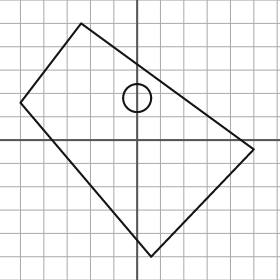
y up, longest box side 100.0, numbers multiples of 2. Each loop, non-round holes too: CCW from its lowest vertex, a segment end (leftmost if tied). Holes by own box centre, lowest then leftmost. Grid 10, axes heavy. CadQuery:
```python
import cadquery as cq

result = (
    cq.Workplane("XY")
    .moveTo(6.0, -50.0)
    .lineTo(50.0, -4.0)
    .lineTo(-24.0, 50.0)
    .lineTo(-50.0, 16.0)
    .close()
    .moveTo(0.0, 18.0)
    .circle(6.0)
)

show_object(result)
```